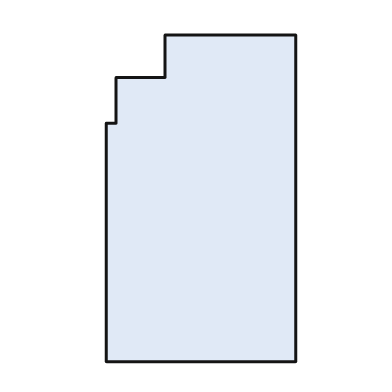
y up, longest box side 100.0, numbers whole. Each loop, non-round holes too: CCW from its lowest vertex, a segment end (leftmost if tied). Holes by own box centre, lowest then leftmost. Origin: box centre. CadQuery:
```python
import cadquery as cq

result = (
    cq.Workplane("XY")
    .moveTo(-29.0, -50.0)
    .lineTo(29.0, -50.0)
    .lineTo(29.0, 50.0)
    .lineTo(-11.0, 50.0)
    .lineTo(-11.0, 37.0)
    .lineTo(-26.0, 37.0)
    .lineTo(-26.0, 23.0)
    .lineTo(-29.0, 23.0)
    .close()
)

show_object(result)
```